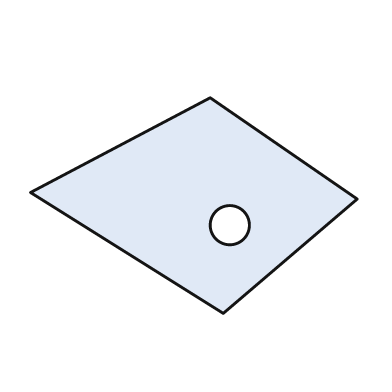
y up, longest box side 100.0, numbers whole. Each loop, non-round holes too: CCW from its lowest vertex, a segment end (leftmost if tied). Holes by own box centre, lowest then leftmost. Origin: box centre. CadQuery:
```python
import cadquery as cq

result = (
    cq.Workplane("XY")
    .moveTo(9.0, -33.0)
    .lineTo(50.0, 2.0)
    .lineTo(5.0, 33.0)
    .lineTo(-50.0, 4.0)
    .close()
    .moveTo(11.0, -6.0)
    .circle(6.0)
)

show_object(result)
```